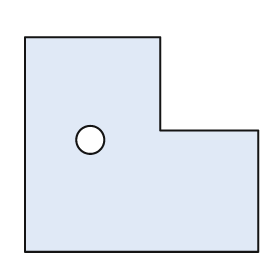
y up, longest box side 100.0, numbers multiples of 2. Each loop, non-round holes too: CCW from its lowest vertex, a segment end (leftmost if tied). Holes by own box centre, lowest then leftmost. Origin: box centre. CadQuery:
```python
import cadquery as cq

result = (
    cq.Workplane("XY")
    .moveTo(-50.0, -46.0)
    .lineTo(50.0, -46.0)
    .lineTo(50.0, 6.0)
    .lineTo(8.0, 6.0)
    .lineTo(8.0, 46.0)
    .lineTo(-50.0, 46.0)
    .close()
    .moveTo(-22.0, 2.0)
    .circle(6.0)
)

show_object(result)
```